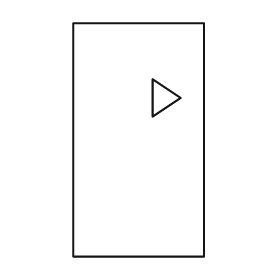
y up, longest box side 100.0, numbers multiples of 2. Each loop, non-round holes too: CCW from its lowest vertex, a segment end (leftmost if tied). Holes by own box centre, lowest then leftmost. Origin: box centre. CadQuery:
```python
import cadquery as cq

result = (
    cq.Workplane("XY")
    .moveTo(-28.0, -50.0)
    .lineTo(28.0, -50.0)
    .lineTo(28.0, 50.0)
    .lineTo(-28.0, 50.0)
    .close()
    .moveTo(6.0, 10.0)
    .lineTo(18.0, 18.0)
    .lineTo(6.0, 26.0)
    .close()
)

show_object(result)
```